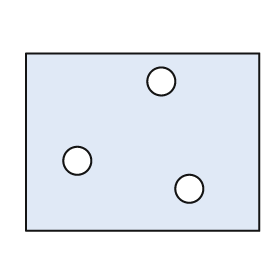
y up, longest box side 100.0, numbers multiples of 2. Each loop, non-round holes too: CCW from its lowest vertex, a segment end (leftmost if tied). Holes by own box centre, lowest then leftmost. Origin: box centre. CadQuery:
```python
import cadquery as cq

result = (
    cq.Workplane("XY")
    .moveTo(-50.0, -38.0)
    .lineTo(50.0, -38.0)
    .lineTo(50.0, 38.0)
    .lineTo(-50.0, 38.0)
    .close()
    .moveTo(20.0, -20.0)
    .circle(6.0)
    .moveTo(-28.0, -8.0)
    .circle(6.0)
    .moveTo(8.0, 26.0)
    .circle(6.0)
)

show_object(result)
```